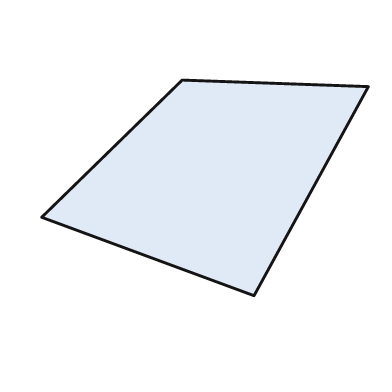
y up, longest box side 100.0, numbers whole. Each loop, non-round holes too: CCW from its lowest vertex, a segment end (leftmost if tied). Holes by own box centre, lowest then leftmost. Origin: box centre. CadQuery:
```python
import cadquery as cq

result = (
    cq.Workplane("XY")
    .moveTo(15.0, -33.0)
    .lineTo(50.0, 31.0)
    .lineTo(-7.0, 33.0)
    .lineTo(-50.0, -9.0)
    .close()
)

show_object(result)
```